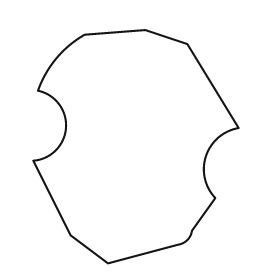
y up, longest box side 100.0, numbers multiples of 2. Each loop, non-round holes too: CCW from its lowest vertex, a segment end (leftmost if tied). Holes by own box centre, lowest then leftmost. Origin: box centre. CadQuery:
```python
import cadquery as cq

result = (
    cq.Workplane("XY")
    .moveTo(-12.0, -50.0)
    .lineTo(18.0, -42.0)
    .threePointArc((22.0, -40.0), (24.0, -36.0))
    .lineTo(34.0, -22.0)
    .threePointArc((30.0, -4.0), (44.0, 8.0))
    .lineTo(22.0, 44.0)
    .lineTo(4.0, 50.0)
    .lineTo(-22.0, 48.0)
    .threePointArc((-34.0, 38.0), (-42.0, 24.0))
    .threePointArc((-30.0, 8.0), (-44.0, -6.0))
    .lineTo(-28.0, -38.0)
    .close()
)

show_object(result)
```